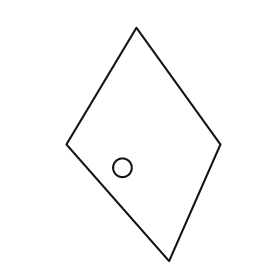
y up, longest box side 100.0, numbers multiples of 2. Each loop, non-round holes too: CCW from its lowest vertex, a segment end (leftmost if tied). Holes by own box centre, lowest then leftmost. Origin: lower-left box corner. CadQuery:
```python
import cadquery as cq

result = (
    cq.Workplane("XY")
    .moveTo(44.0, 0.0)
    .lineTo(66.0, 50.0)
    .lineTo(30.0, 100.0)
    .lineTo(0.0, 50.0)
    .close()
    .moveTo(24.0, 40.0)
    .circle(4.0)
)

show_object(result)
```